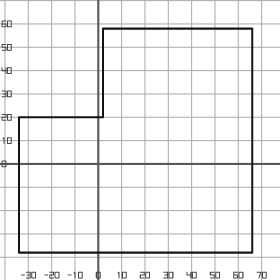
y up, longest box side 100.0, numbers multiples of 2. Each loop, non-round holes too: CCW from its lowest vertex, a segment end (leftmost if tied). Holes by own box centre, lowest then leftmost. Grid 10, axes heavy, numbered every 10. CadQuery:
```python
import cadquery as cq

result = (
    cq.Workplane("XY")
    .moveTo(-34.0, -38.0)
    .lineTo(66.0, -38.0)
    .lineTo(66.0, 58.0)
    .lineTo(2.0, 58.0)
    .lineTo(2.0, 20.0)
    .lineTo(-34.0, 20.0)
    .close()
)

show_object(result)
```